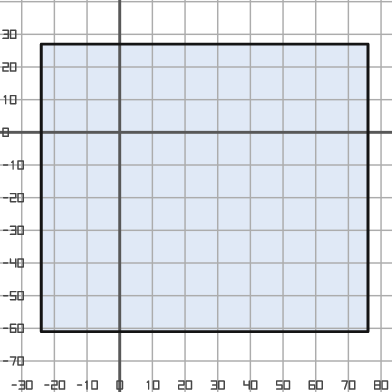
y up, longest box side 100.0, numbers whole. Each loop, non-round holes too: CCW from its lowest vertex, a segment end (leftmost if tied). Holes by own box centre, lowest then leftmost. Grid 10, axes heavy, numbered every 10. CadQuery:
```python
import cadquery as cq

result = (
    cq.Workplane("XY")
    .moveTo(-24.0, -61.0)
    .lineTo(76.0, -61.0)
    .lineTo(76.0, 27.0)
    .lineTo(-24.0, 27.0)
    .close()
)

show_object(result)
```